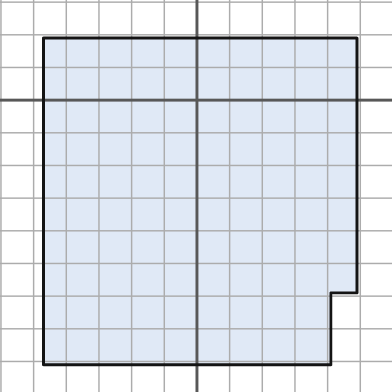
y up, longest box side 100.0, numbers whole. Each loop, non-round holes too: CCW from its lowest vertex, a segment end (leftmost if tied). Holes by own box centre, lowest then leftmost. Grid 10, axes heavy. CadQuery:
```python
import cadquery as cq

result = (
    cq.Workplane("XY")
    .moveTo(-47.0, -81.0)
    .lineTo(41.0, -81.0)
    .lineTo(41.0, -59.0)
    .lineTo(49.0, -59.0)
    .lineTo(49.0, 19.0)
    .lineTo(-47.0, 19.0)
    .close()
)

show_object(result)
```